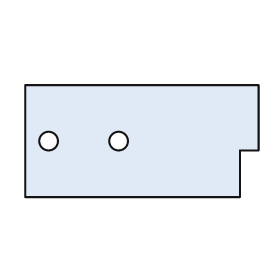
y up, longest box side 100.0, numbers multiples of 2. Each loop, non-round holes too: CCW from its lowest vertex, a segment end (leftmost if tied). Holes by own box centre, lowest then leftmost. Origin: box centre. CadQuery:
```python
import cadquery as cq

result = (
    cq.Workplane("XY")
    .moveTo(-50.0, -24.0)
    .lineTo(42.0, -24.0)
    .lineTo(42.0, -4.0)
    .lineTo(50.0, -4.0)
    .lineTo(50.0, 24.0)
    .lineTo(-50.0, 24.0)
    .close()
    .moveTo(-40.0, 0.0)
    .circle(4.0)
    .moveTo(-10.0, 0.0)
    .circle(4.0)
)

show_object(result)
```